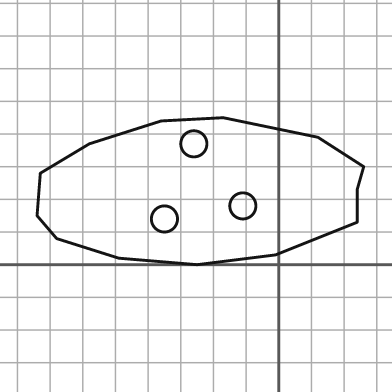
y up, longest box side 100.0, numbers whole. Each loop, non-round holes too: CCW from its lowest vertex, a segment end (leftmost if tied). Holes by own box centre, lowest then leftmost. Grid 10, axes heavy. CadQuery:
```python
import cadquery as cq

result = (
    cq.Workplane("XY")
    .moveTo(-25.0, 0.0)
    .lineTo(-1.0, 3.0)
    .lineTo(24.0, 13.0)
    .lineTo(24.0, 23.0)
    .lineTo(26.0, 30.0)
    .lineTo(12.0, 39.0)
    .lineTo(-17.0, 45.0)
    .lineTo(-36.0, 44.0)
    .lineTo(-58.0, 37.0)
    .lineTo(-73.0, 28.0)
    .lineTo(-74.0, 15.0)
    .lineTo(-68.0, 8.0)
    .lineTo(-49.0, 2.0)
    .close()
    .moveTo(-35.0, 14.0)
    .circle(4.0)
    .moveTo(-11.0, 18.0)
    .circle(4.0)
    .moveTo(-26.0, 37.0)
    .circle(4.0)
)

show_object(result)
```